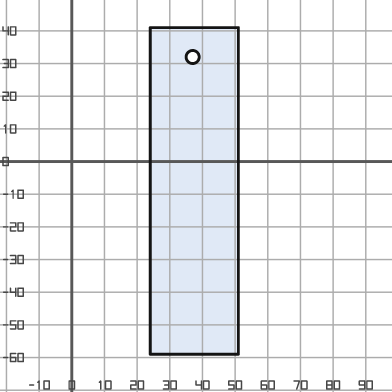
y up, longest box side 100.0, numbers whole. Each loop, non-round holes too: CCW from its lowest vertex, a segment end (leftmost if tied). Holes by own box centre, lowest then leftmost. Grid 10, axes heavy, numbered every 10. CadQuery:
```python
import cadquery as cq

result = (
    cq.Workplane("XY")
    .moveTo(24.0, -59.0)
    .lineTo(51.0, -59.0)
    .lineTo(51.0, 41.0)
    .lineTo(24.0, 41.0)
    .close()
    .moveTo(37.0, 32.0)
    .circle(2.0)
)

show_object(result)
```